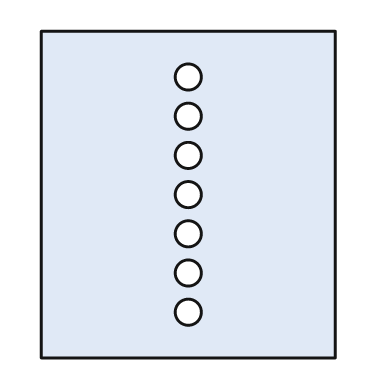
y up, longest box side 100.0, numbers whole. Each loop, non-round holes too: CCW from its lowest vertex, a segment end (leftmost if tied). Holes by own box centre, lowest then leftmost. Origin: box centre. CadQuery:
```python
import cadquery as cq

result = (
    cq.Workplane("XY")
    .moveTo(-45.0, -50.0)
    .lineTo(45.0, -50.0)
    .lineTo(45.0, 50.0)
    .lineTo(-45.0, 50.0)
    .close()
    .moveTo(0.0, -36.0)
    .circle(4.0)
    .moveTo(0.0, -24.0)
    .circle(4.0)
    .moveTo(0.0, -12.0)
    .circle(4.0)
    .moveTo(0.0, 0.0)
    .circle(4.0)
    .moveTo(0.0, 12.0)
    .circle(4.0)
    .moveTo(0.0, 24.0)
    .circle(4.0)
    .moveTo(0.0, 36.0)
    .circle(4.0)
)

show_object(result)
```